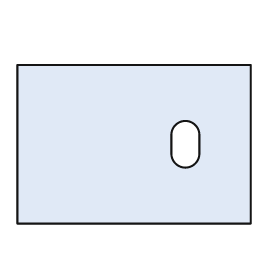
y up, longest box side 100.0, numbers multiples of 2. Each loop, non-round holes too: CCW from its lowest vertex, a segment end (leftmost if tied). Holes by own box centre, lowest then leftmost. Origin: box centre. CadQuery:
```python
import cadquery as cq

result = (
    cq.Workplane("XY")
    .moveTo(-50.0, -34.0)
    .lineTo(50.0, -34.0)
    .lineTo(50.0, 34.0)
    .lineTo(-50.0, 34.0)
    .close()
    .moveTo(16.0, -4.0)
    .threePointArc((22.0, -10.0), (28.0, -4.0))
    .lineTo(28.0, 4.0)
    .threePointArc((22.0, 10.0), (16.0, 4.0))
    .close()
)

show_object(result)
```